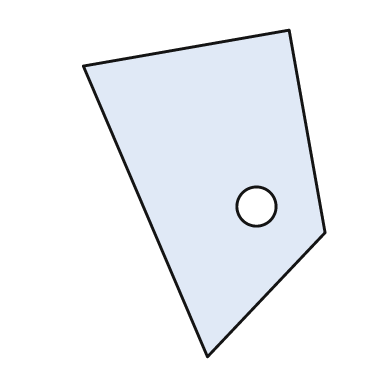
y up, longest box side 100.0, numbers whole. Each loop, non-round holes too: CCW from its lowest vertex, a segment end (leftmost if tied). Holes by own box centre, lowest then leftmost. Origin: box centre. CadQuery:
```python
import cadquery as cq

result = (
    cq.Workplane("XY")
    .moveTo(1.0, -50.0)
    .lineTo(37.0, -12.0)
    .lineTo(26.0, 50.0)
    .lineTo(-37.0, 39.0)
    .close()
    .moveTo(16.0, -4.0)
    .circle(6.0)
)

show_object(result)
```